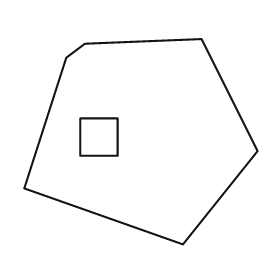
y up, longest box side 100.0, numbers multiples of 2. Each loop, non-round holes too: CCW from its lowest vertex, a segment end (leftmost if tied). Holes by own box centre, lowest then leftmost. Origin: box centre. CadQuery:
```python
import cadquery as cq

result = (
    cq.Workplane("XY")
    .moveTo(18.0, -44.0)
    .lineTo(50.0, -4.0)
    .lineTo(26.0, 44.0)
    .lineTo(-24.0, 42.0)
    .lineTo(-32.0, 36.0)
    .lineTo(-50.0, -20.0)
    .close()
    .moveTo(-26.0, -6.0)
    .lineTo(-10.0, -6.0)
    .lineTo(-10.0, 10.0)
    .lineTo(-26.0, 10.0)
    .close()
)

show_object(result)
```